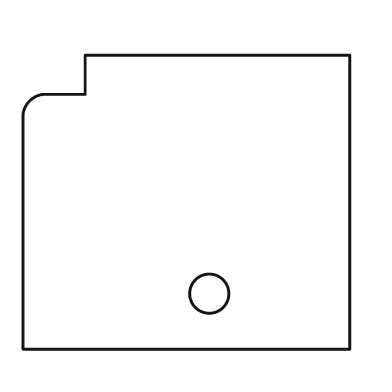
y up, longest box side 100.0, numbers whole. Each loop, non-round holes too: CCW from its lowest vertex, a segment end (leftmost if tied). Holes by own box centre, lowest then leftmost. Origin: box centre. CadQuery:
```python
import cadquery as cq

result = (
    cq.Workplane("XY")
    .moveTo(-50.0, -45.0)
    .lineTo(50.0, -45.0)
    .lineTo(50.0, 45.0)
    .lineTo(-31.0, 45.0)
    .lineTo(-31.0, 33.0)
    .lineTo(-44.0, 33.0)
    .threePointArc((-48.0, 31.0), (-50.0, 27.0))
    .close()
    .moveTo(7.0, -28.0)
    .circle(6.0)
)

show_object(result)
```